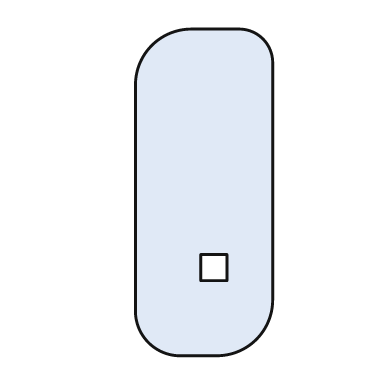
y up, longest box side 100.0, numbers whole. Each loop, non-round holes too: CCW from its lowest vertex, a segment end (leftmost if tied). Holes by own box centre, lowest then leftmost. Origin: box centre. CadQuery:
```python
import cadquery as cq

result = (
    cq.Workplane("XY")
    .moveTo(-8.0, -50.0)
    .lineTo(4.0, -50.0)
    .threePointArc((16.0, -45.0), (21.0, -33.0))
    .lineTo(21.0, 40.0)
    .threePointArc((18.0, 47.0), (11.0, 50.0))
    .lineTo(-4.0, 50.0)
    .threePointArc((-16.0, 45.0), (-21.0, 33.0))
    .lineTo(-21.0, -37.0)
    .threePointArc((-17.0, -46.0), (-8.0, -50.0))
    .close()
    .moveTo(-1.0, -27.0)
    .lineTo(7.0, -27.0)
    .lineTo(7.0, -19.0)
    .lineTo(-1.0, -19.0)
    .close()
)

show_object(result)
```